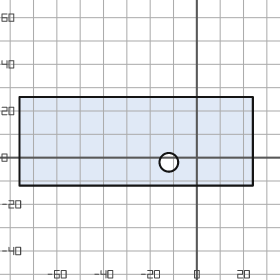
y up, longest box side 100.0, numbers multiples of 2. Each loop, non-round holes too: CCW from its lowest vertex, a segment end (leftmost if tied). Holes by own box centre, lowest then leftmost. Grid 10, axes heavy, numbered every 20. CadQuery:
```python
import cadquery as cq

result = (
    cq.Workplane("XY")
    .moveTo(-76.0, -12.0)
    .lineTo(24.0, -12.0)
    .lineTo(24.0, 26.0)
    .lineTo(-76.0, 26.0)
    .close()
    .moveTo(-12.0, -2.0)
    .circle(4.0)
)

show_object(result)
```